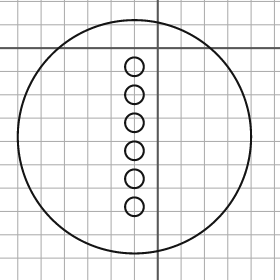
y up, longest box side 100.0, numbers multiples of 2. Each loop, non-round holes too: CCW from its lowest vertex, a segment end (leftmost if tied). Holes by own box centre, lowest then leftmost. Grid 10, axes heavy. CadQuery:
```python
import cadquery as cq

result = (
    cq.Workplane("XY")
    .moveTo(-10.0, -38.0)
    .circle(50.0)
    .moveTo(-10.0, -68.0)
    .circle(4.0)
    .moveTo(-10.0, -56.0)
    .circle(4.0)
    .moveTo(-10.0, -44.0)
    .circle(4.0)
    .moveTo(-10.0, -32.0)
    .circle(4.0)
    .moveTo(-10.0, -20.0)
    .circle(4.0)
    .moveTo(-10.0, -8.0)
    .circle(4.0)
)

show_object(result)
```